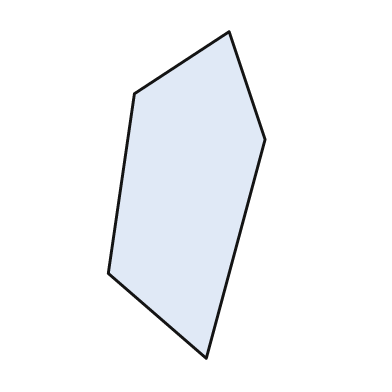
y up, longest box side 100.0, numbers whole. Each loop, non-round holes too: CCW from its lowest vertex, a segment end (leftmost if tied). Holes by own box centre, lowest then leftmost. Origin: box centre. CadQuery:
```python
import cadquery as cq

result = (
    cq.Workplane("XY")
    .moveTo(6.0, -50.0)
    .lineTo(24.0, 17.0)
    .lineTo(13.0, 50.0)
    .lineTo(-16.0, 31.0)
    .lineTo(-24.0, -24.0)
    .close()
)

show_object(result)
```